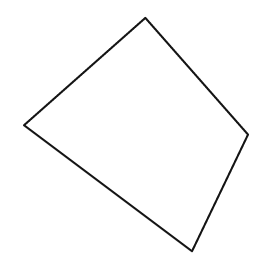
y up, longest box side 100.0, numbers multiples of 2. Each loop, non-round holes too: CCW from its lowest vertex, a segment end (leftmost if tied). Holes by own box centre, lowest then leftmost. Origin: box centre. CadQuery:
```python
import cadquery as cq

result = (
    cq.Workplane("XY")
    .moveTo(24.0, -50.0)
    .lineTo(48.0, 0.0)
    .lineTo(4.0, 50.0)
    .lineTo(-48.0, 4.0)
    .close()
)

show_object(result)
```